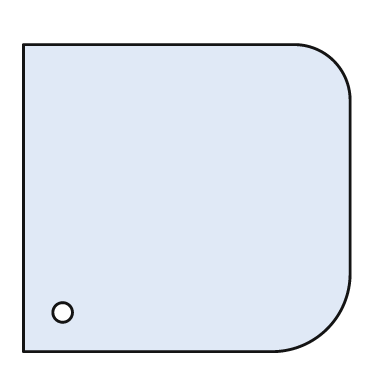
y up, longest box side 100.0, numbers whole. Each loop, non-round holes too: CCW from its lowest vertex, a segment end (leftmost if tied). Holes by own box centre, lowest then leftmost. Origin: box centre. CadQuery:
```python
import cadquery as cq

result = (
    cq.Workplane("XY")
    .moveTo(-50.0, -47.0)
    .lineTo(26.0, -47.0)
    .threePointArc((43.0, -40.0), (50.0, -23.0))
    .lineTo(50.0, 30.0)
    .threePointArc((45.0, 42.0), (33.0, 47.0))
    .lineTo(-50.0, 47.0)
    .close()
    .moveTo(-38.0, -35.0)
    .circle(3.0)
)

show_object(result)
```